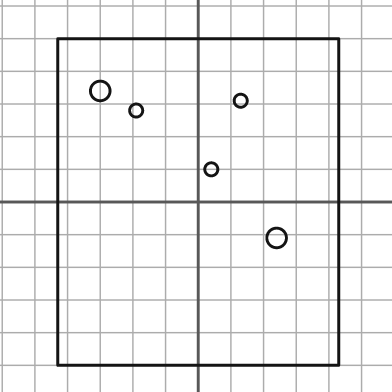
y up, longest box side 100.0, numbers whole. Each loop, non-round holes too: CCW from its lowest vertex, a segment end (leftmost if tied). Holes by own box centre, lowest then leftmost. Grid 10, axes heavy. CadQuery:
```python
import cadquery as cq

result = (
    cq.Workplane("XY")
    .moveTo(-43.0, -50.0)
    .lineTo(43.0, -50.0)
    .lineTo(43.0, 50.0)
    .lineTo(-43.0, 50.0)
    .close()
    .moveTo(24.0, -11.0)
    .circle(3.0)
    .moveTo(4.0, 10.0)
    .circle(2.0)
    .moveTo(-19.0, 28.0)
    .circle(2.0)
    .moveTo(13.0, 31.0)
    .circle(2.0)
    .moveTo(-30.0, 34.0)
    .circle(3.0)
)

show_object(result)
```